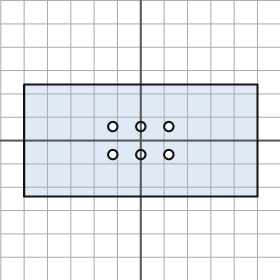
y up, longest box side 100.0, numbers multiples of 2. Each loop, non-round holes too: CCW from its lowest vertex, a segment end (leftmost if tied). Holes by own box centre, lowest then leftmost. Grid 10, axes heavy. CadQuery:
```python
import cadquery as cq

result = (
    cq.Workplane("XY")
    .moveTo(-50.0, -24.0)
    .lineTo(50.0, -24.0)
    .lineTo(50.0, 24.0)
    .lineTo(-50.0, 24.0)
    .close()
    .moveTo(-12.0, -6.0)
    .circle(2.0)
    .moveTo(0.0, -6.0)
    .circle(2.0)
    .moveTo(12.0, -6.0)
    .circle(2.0)
    .moveTo(-12.0, 6.0)
    .circle(2.0)
    .moveTo(0.0, 6.0)
    .circle(2.0)
    .moveTo(12.0, 6.0)
    .circle(2.0)
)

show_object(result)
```